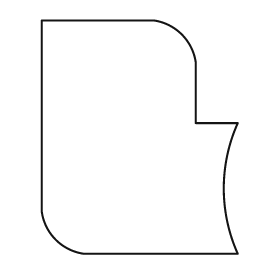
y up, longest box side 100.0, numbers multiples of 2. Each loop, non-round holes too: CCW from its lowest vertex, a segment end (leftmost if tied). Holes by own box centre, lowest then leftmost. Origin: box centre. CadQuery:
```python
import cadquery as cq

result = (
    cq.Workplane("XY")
    .moveTo(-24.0, -50.0)
    .lineTo(42.0, -50.0)
    .threePointArc((36.0, -22.0), (42.0, 6.0))
    .lineTo(24.0, 6.0)
    .lineTo(24.0, 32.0)
    .threePointArc((18.0, 44.0), (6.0, 50.0))
    .lineTo(-42.0, 50.0)
    .lineTo(-42.0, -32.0)
    .threePointArc((-36.0, -44.0), (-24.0, -50.0))
    .close()
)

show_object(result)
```